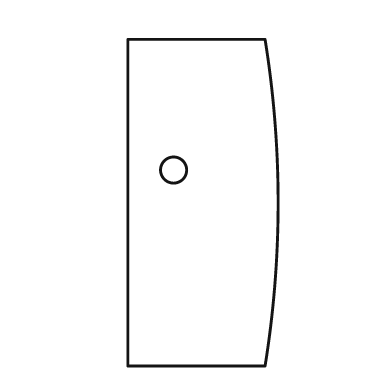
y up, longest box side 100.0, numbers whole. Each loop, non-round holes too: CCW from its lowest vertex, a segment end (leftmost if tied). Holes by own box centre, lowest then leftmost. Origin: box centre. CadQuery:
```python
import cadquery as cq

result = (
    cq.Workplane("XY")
    .moveTo(-23.0, -50.0)
    .lineTo(19.0, -50.0)
    .threePointArc((23.0, 0.0), (19.0, 50.0))
    .lineTo(-23.0, 50.0)
    .close()
    .moveTo(-9.0, 10.0)
    .circle(4.0)
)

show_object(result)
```